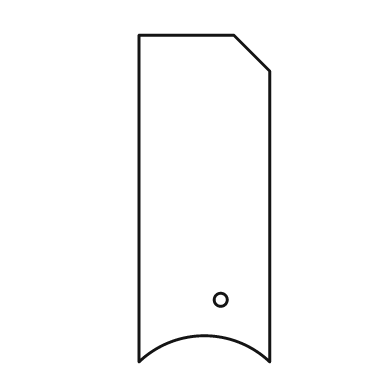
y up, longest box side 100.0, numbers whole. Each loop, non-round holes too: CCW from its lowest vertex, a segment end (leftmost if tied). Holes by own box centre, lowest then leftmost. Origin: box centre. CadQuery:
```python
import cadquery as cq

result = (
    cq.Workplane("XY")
    .moveTo(-20.0, -50.0)
    .threePointArc((0.0, -42.0), (20.0, -50.0))
    .lineTo(20.0, 39.0)
    .lineTo(9.0, 50.0)
    .lineTo(-20.0, 50.0)
    .close()
    .moveTo(5.0, -31.0)
    .circle(2.0)
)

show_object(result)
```